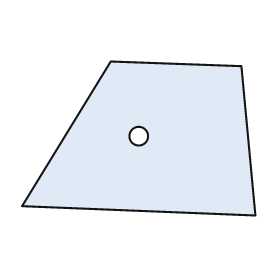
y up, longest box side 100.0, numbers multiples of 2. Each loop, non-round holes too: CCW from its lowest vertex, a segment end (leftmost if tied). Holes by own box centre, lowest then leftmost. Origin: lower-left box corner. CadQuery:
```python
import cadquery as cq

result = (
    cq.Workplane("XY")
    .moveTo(100.0, 0.0)
    .lineTo(94.0, 64.0)
    .lineTo(38.0, 66.0)
    .lineTo(0.0, 4.0)
    .close()
    .moveTo(50.0, 34.0)
    .circle(4.0)
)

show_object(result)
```